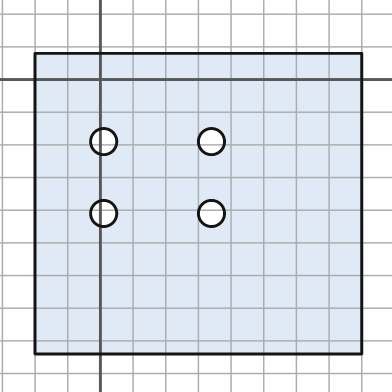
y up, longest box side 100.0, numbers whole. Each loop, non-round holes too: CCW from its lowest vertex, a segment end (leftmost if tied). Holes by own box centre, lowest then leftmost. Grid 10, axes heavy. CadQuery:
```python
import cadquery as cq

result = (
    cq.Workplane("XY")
    .moveTo(-20.0, -84.0)
    .lineTo(80.0, -84.0)
    .lineTo(80.0, 8.0)
    .lineTo(-20.0, 8.0)
    .close()
    .moveTo(1.0, -41.0)
    .circle(4.0)
    .moveTo(34.0, -41.0)
    .circle(4.0)
    .moveTo(1.0, -19.0)
    .circle(4.0)
    .moveTo(34.0, -19.0)
    .circle(4.0)
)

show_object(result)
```